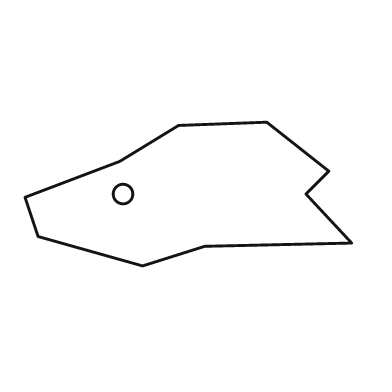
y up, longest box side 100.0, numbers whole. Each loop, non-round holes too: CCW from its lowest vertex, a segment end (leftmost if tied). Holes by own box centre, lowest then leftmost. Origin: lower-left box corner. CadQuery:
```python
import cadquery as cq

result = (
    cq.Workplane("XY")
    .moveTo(36.0, 0.0)
    .lineTo(55.0, 6.0)
    .lineTo(100.0, 7.0)
    .lineTo(86.0, 22.0)
    .lineTo(93.0, 29.0)
    .lineTo(74.0, 44.0)
    .lineTo(47.0, 43.0)
    .lineTo(29.0, 32.0)
    .lineTo(0.0, 21.0)
    .lineTo(4.0, 9.0)
    .close()
    .moveTo(30.0, 22.0)
    .circle(3.0)
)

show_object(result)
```